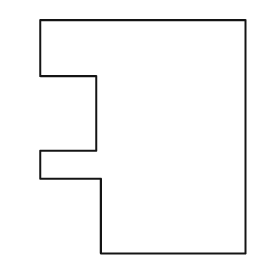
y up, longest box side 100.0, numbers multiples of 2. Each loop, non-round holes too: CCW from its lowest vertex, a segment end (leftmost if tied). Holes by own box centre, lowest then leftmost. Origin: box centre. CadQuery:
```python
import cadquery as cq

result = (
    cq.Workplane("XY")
    .moveTo(-18.0, -50.0)
    .lineTo(44.0, -50.0)
    .lineTo(44.0, 50.0)
    .lineTo(-44.0, 50.0)
    .lineTo(-44.0, 26.0)
    .lineTo(-20.0, 26.0)
    .lineTo(-20.0, -6.0)
    .lineTo(-44.0, -6.0)
    .lineTo(-44.0, -18.0)
    .lineTo(-18.0, -18.0)
    .close()
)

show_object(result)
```